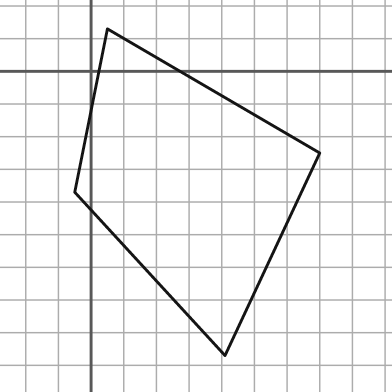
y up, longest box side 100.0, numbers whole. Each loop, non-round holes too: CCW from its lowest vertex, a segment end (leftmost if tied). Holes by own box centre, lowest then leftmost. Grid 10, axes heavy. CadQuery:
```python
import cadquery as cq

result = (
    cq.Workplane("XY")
    .moveTo(41.0, -87.0)
    .lineTo(70.0, -25.0)
    .lineTo(5.0, 13.0)
    .lineTo(-5.0, -37.0)
    .close()
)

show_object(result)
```